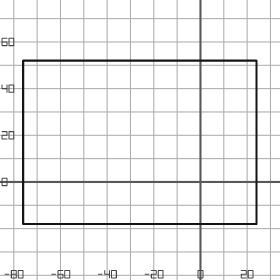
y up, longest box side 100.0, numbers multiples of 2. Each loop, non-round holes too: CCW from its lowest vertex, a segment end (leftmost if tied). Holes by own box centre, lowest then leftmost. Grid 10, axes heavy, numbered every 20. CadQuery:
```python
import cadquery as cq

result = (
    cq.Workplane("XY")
    .moveTo(-76.0, -18.0)
    .lineTo(24.0, -18.0)
    .lineTo(24.0, 52.0)
    .lineTo(-76.0, 52.0)
    .close()
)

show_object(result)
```